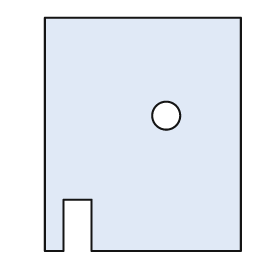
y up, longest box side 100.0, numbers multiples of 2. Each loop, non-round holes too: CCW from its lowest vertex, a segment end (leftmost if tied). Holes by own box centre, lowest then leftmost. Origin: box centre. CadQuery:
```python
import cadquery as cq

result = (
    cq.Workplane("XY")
    .moveTo(-42.0, -50.0)
    .lineTo(-34.0, -50.0)
    .lineTo(-34.0, -28.0)
    .lineTo(-22.0, -28.0)
    .lineTo(-22.0, -50.0)
    .lineTo(42.0, -50.0)
    .lineTo(42.0, 50.0)
    .lineTo(-42.0, 50.0)
    .close()
    .moveTo(10.0, 8.0)
    .circle(6.0)
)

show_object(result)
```